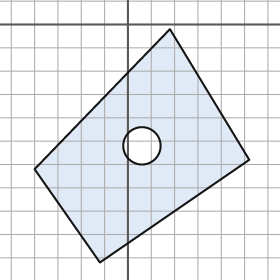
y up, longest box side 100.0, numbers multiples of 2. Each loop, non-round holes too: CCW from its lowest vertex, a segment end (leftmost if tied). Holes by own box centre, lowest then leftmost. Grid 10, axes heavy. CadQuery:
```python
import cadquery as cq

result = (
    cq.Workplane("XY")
    .moveTo(-12.0, -102.0)
    .lineTo(52.0, -58.0)
    .lineTo(18.0, -2.0)
    .lineTo(-40.0, -62.0)
    .close()
    .moveTo(6.0, -52.0)
    .circle(8.0)
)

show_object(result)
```